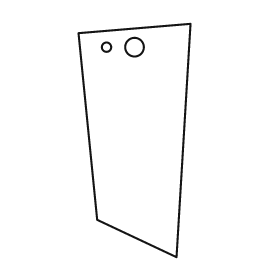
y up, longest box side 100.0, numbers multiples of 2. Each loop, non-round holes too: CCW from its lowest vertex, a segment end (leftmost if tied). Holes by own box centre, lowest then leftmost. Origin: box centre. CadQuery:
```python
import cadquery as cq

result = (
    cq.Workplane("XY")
    .moveTo(18.0, -50.0)
    .lineTo(24.0, 50.0)
    .lineTo(-24.0, 46.0)
    .lineTo(-16.0, -34.0)
    .close()
    .moveTo(-12.0, 40.0)
    .circle(2.0)
    .moveTo(0.0, 40.0)
    .circle(4.0)
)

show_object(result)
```